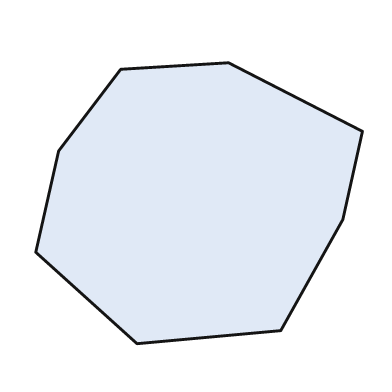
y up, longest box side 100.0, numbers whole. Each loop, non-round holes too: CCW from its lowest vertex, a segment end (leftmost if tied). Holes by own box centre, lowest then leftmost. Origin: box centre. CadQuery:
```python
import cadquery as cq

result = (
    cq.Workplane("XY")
    .moveTo(-19.0, -43.0)
    .lineTo(25.0, -39.0)
    .lineTo(44.0, -5.0)
    .lineTo(50.0, 22.0)
    .lineTo(9.0, 43.0)
    .lineTo(-24.0, 41.0)
    .lineTo(-43.0, 16.0)
    .lineTo(-50.0, -15.0)
    .close()
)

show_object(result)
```